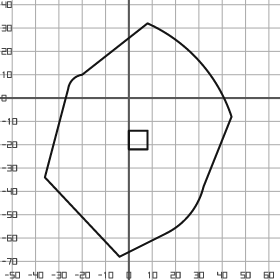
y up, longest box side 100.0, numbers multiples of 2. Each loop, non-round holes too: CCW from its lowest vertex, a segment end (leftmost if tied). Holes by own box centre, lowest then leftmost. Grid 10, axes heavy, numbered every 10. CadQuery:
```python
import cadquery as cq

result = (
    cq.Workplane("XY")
    .moveTo(-4.0, -68.0)
    .lineTo(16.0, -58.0)
    .threePointArc((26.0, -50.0), (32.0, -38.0))
    .lineTo(44.0, -8.0)
    .threePointArc((30.0, 16.0), (8.0, 32.0))
    .lineTo(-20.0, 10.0)
    .threePointArc((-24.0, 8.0), (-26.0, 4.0))
    .lineTo(-36.0, -34.0)
    .close()
    .moveTo(0.0, -22.0)
    .lineTo(8.0, -22.0)
    .lineTo(8.0, -14.0)
    .lineTo(0.0, -14.0)
    .close()
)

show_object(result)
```